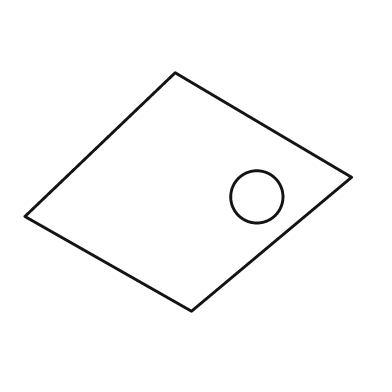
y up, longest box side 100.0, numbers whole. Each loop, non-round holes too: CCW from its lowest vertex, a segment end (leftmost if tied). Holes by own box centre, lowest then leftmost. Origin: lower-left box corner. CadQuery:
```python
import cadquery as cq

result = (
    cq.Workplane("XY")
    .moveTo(51.0, 0.0)
    .lineTo(100.0, 41.0)
    .lineTo(46.0, 73.0)
    .lineTo(0.0, 29.0)
    .close()
    .moveTo(71.0, 35.0)
    .circle(8.0)
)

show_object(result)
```